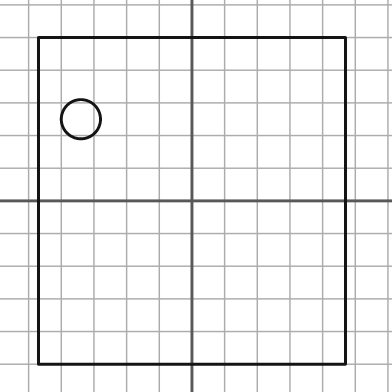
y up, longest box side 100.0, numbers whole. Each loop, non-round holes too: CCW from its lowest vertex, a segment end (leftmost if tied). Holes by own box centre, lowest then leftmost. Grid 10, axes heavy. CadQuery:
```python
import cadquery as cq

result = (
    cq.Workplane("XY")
    .moveTo(-47.0, -50.0)
    .lineTo(47.0, -50.0)
    .lineTo(47.0, 50.0)
    .lineTo(-47.0, 50.0)
    .close()
    .moveTo(-34.0, 25.0)
    .circle(6.0)
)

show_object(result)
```